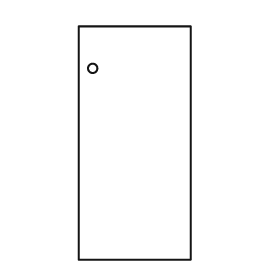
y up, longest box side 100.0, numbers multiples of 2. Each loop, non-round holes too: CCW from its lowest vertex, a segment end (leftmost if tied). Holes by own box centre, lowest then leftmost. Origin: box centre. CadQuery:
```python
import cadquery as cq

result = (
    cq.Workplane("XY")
    .moveTo(-24.0, -50.0)
    .lineTo(24.0, -50.0)
    .lineTo(24.0, 50.0)
    .lineTo(-24.0, 50.0)
    .close()
    .moveTo(-18.0, 32.0)
    .circle(2.0)
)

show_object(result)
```